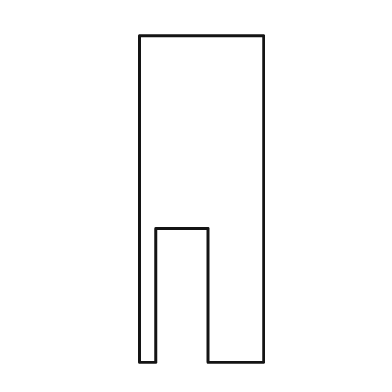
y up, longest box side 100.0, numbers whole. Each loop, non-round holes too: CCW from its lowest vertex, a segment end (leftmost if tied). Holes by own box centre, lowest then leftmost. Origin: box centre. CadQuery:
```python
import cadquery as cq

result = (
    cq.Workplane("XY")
    .moveTo(-19.0, -50.0)
    .lineTo(-14.0, -50.0)
    .lineTo(-14.0, -9.0)
    .lineTo(2.0, -9.0)
    .lineTo(2.0, -50.0)
    .lineTo(19.0, -50.0)
    .lineTo(19.0, 50.0)
    .lineTo(-19.0, 50.0)
    .close()
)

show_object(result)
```